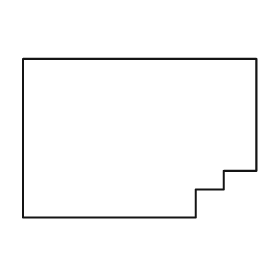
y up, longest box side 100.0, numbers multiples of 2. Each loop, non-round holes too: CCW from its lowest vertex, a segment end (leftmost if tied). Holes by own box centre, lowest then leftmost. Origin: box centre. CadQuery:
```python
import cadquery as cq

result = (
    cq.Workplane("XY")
    .moveTo(-50.0, -34.0)
    .lineTo(24.0, -34.0)
    .lineTo(24.0, -22.0)
    .lineTo(36.0, -22.0)
    .lineTo(36.0, -14.0)
    .lineTo(50.0, -14.0)
    .lineTo(50.0, 34.0)
    .lineTo(-50.0, 34.0)
    .close()
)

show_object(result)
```